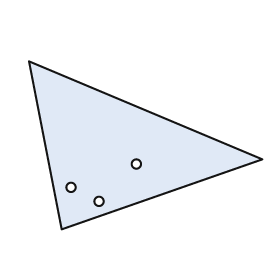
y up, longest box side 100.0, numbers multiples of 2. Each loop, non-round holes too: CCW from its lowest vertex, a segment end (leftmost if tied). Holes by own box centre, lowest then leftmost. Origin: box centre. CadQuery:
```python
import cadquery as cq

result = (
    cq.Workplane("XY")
    .moveTo(-36.0, -36.0)
    .lineTo(50.0, -6.0)
    .lineTo(-50.0, 36.0)
    .close()
    .moveTo(-20.0, -24.0)
    .circle(2.0)
    .moveTo(-32.0, -18.0)
    .circle(2.0)
    .moveTo(-4.0, -8.0)
    .circle(2.0)
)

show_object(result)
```